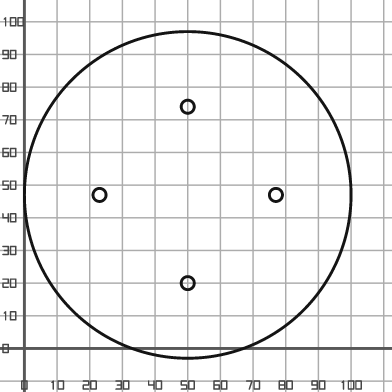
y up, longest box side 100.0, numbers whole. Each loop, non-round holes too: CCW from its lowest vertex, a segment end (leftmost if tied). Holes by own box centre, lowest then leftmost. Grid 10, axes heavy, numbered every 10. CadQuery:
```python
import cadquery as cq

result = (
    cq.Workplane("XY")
    .moveTo(50.0, 47.0)
    .circle(50.0)
    .moveTo(50.0, 20.0)
    .circle(2.0)
    .moveTo(23.0, 47.0)
    .circle(2.0)
    .moveTo(77.0, 47.0)
    .circle(2.0)
    .moveTo(50.0, 74.0)
    .circle(2.0)
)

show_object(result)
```